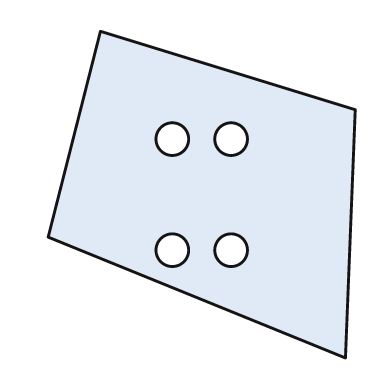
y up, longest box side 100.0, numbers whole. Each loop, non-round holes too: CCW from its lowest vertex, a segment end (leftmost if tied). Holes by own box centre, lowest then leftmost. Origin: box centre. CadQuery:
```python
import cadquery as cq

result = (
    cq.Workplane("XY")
    .moveTo(44.0, -50.0)
    .lineTo(47.0, 26.0)
    .lineTo(-31.0, 50.0)
    .lineTo(-47.0, -13.0)
    .close()
    .moveTo(-9.0, -17.0)
    .circle(5.0)
    .moveTo(9.0, -17.0)
    .circle(5.0)
    .moveTo(-9.0, 17.0)
    .circle(5.0)
    .moveTo(9.0, 17.0)
    .circle(5.0)
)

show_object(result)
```